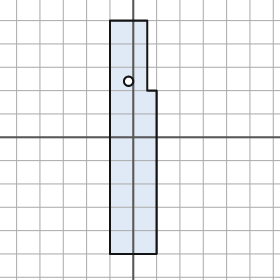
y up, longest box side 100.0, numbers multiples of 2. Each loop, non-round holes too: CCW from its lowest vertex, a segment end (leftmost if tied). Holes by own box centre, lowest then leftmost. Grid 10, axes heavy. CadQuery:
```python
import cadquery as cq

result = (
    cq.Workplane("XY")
    .moveTo(-10.0, -50.0)
    .lineTo(10.0, -50.0)
    .lineTo(10.0, 20.0)
    .lineTo(6.0, 20.0)
    .lineTo(6.0, 50.0)
    .lineTo(-10.0, 50.0)
    .close()
    .moveTo(-2.0, 24.0)
    .circle(2.0)
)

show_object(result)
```